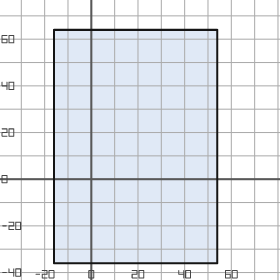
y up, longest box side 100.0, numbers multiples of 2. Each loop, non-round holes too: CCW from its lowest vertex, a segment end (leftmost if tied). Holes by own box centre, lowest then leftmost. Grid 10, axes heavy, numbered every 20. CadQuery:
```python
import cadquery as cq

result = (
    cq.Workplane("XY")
    .moveTo(-16.0, -36.0)
    .lineTo(54.0, -36.0)
    .lineTo(54.0, 64.0)
    .lineTo(-16.0, 64.0)
    .close()
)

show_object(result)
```